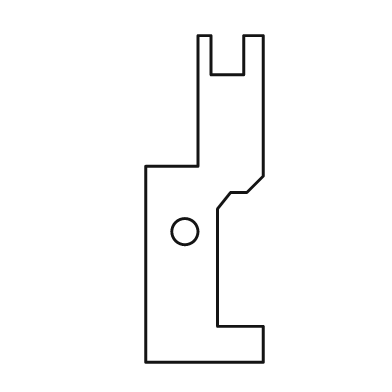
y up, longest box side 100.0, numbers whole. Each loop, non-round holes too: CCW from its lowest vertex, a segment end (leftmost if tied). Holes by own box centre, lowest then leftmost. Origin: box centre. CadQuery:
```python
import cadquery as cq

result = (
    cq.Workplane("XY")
    .moveTo(-18.0, -50.0)
    .lineTo(18.0, -50.0)
    .lineTo(18.0, -39.0)
    .lineTo(4.0, -39.0)
    .lineTo(4.0, -3.0)
    .lineTo(8.0, 2.0)
    .lineTo(13.0, 2.0)
    .lineTo(18.0, 7.0)
    .lineTo(18.0, 50.0)
    .lineTo(12.0, 50.0)
    .lineTo(12.0, 38.0)
    .lineTo(2.0, 38.0)
    .lineTo(2.0, 50.0)
    .lineTo(-2.0, 50.0)
    .lineTo(-2.0, 10.0)
    .lineTo(-18.0, 10.0)
    .close()
    .moveTo(-6.0, -10.0)
    .circle(4.0)
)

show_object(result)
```